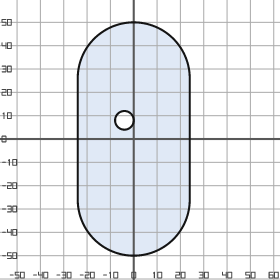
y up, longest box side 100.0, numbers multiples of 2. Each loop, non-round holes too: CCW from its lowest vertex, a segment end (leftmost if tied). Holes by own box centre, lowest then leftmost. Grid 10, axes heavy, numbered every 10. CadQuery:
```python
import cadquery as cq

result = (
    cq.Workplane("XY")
    .moveTo(-24.0, -26.0)
    .threePointArc((0.0, -50.0), (24.0, -26.0))
    .lineTo(24.0, 26.0)
    .threePointArc((0.0, 50.0), (-24.0, 26.0))
    .close()
    .moveTo(-4.0, 8.0)
    .circle(4.0)
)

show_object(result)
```